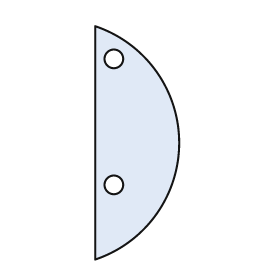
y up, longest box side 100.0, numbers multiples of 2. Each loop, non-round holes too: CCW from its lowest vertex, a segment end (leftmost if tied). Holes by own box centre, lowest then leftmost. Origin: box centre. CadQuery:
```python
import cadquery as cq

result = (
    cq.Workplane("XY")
    .moveTo(-18.0, -50.0)
    .threePointArc((18.0, 0.0), (-18.0, 50.0))
    .close()
    .moveTo(-10.0, -18.0)
    .circle(4.0)
    .moveTo(-10.0, 36.0)
    .circle(4.0)
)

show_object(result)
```